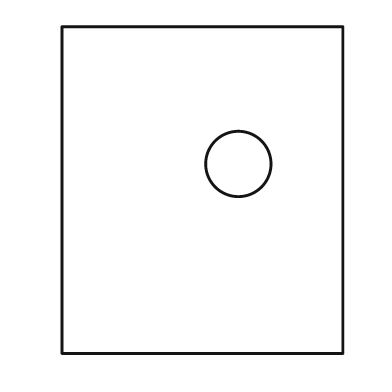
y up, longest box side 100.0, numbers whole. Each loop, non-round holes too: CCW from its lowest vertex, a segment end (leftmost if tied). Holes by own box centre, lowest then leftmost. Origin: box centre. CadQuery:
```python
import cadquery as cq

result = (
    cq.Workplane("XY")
    .moveTo(-43.0, -50.0)
    .lineTo(43.0, -50.0)
    .lineTo(43.0, 50.0)
    .lineTo(-43.0, 50.0)
    .close()
    .moveTo(11.0, 8.0)
    .circle(10.0)
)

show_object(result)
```